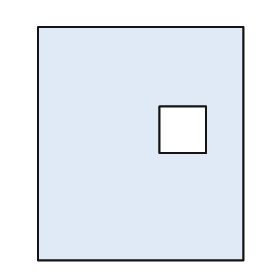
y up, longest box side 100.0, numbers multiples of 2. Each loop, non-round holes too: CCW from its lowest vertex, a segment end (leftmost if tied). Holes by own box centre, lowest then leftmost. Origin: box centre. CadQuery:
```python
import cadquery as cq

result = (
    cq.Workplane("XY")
    .moveTo(-44.0, -50.0)
    .lineTo(44.0, -50.0)
    .lineTo(44.0, 50.0)
    .lineTo(-44.0, 50.0)
    .close()
    .moveTo(8.0, -4.0)
    .lineTo(28.0, -4.0)
    .lineTo(28.0, 16.0)
    .lineTo(8.0, 16.0)
    .close()
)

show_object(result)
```